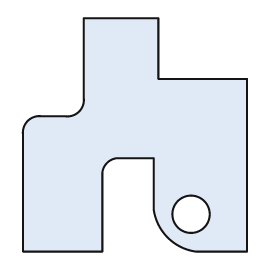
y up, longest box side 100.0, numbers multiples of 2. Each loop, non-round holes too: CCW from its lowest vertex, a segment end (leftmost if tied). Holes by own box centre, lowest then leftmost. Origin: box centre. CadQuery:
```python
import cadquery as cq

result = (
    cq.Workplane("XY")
    .moveTo(-48.0, -50.0)
    .lineTo(-14.0, -50.0)
    .lineTo(-14.0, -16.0)
    .threePointArc((-12.0, -12.0), (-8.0, -10.0))
    .lineTo(8.0, -10.0)
    .lineTo(8.0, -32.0)
    .threePointArc((14.0, -44.0), (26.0, -50.0))
    .lineTo(48.0, -50.0)
    .lineTo(48.0, 24.0)
    .lineTo(10.0, 24.0)
    .lineTo(10.0, 50.0)
    .lineTo(-22.0, 50.0)
    .lineTo(-22.0, 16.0)
    .threePointArc((-24.0, 10.0), (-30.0, 8.0))
    .lineTo(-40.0, 8.0)
    .threePointArc((-46.0, 6.0), (-48.0, 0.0))
    .close()
    .moveTo(24.0, -34.0)
    .circle(8.0)
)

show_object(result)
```